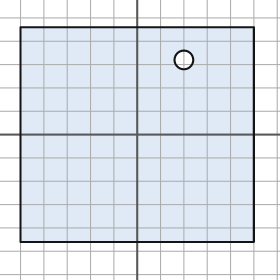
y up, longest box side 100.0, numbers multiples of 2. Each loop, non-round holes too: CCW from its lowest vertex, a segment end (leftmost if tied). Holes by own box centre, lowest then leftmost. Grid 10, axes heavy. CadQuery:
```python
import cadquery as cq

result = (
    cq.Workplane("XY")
    .moveTo(-50.0, -46.0)
    .lineTo(50.0, -46.0)
    .lineTo(50.0, 46.0)
    .lineTo(-50.0, 46.0)
    .close()
    .moveTo(20.0, 32.0)
    .circle(4.0)
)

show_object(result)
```